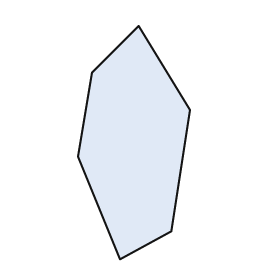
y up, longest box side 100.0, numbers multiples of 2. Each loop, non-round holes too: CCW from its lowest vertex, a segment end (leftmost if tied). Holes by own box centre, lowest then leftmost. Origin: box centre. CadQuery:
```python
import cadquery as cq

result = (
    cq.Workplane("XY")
    .moveTo(-6.0, -50.0)
    .lineTo(16.0, -38.0)
    .lineTo(24.0, 14.0)
    .lineTo(2.0, 50.0)
    .lineTo(-18.0, 30.0)
    .lineTo(-24.0, -6.0)
    .close()
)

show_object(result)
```